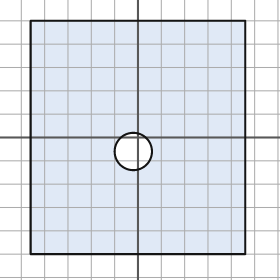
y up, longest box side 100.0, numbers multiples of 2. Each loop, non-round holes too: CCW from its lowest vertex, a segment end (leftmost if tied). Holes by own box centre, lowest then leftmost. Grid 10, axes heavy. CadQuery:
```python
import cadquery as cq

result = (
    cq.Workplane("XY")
    .moveTo(-46.0, -50.0)
    .lineTo(46.0, -50.0)
    .lineTo(46.0, 50.0)
    .lineTo(-46.0, 50.0)
    .close()
    .moveTo(-2.0, -6.0)
    .circle(8.0)
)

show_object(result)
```